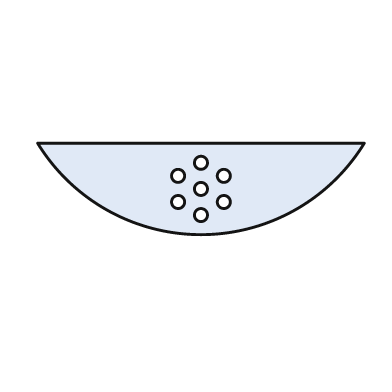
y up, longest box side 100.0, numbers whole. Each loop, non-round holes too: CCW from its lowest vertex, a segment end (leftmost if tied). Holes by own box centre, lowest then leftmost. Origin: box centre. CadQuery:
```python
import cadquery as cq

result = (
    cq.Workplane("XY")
    .moveTo(-50.0, 14.0)
    .threePointArc((0.0, -14.0), (50.0, 14.0))
    .close()
    .moveTo(0.0, -8.0)
    .circle(2.0)
    .moveTo(-7.0, -4.0)
    .circle(2.0)
    .moveTo(7.0, -4.0)
    .circle(2.0)
    .moveTo(0.0, 0.0)
    .circle(2.0)
    .moveTo(-7.0, 4.0)
    .circle(2.0)
    .moveTo(7.0, 4.0)
    .circle(2.0)
    .moveTo(0.0, 8.0)
    .circle(2.0)
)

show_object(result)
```